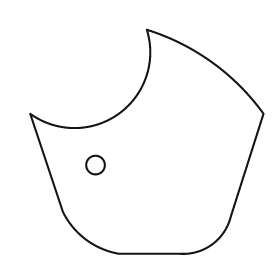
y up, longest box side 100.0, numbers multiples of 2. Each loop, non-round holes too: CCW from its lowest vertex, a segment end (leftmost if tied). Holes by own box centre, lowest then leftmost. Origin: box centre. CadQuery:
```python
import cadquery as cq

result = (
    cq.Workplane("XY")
    .moveTo(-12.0, -48.0)
    .lineTo(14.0, -48.0)
    .threePointArc((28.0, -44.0), (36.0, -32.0))
    .lineTo(50.0, 12.0)
    .threePointArc((28.0, 34.0), (0.0, 48.0))
    .threePointArc((-12.0, 12.0), (-50.0, 12.0))
    .lineTo(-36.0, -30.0)
    .threePointArc((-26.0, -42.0), (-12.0, -48.0))
    .close()
    .moveTo(-22.0, -10.0)
    .circle(4.0)
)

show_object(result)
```